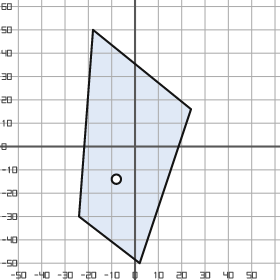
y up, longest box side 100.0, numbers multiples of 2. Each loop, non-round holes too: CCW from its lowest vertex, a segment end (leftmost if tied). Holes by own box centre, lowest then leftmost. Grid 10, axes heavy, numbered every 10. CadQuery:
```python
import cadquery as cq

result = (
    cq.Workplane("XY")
    .moveTo(2.0, -50.0)
    .lineTo(24.0, 16.0)
    .lineTo(-18.0, 50.0)
    .lineTo(-24.0, -30.0)
    .close()
    .moveTo(-8.0, -14.0)
    .circle(2.0)
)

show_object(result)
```